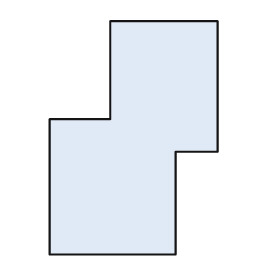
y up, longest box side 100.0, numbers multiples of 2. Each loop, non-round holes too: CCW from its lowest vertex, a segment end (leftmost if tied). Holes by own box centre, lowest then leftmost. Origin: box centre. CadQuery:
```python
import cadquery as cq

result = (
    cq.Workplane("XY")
    .moveTo(-36.0, -50.0)
    .lineTo(18.0, -50.0)
    .lineTo(18.0, -6.0)
    .lineTo(36.0, -6.0)
    .lineTo(36.0, 50.0)
    .lineTo(-10.0, 50.0)
    .lineTo(-10.0, 8.0)
    .lineTo(-36.0, 8.0)
    .close()
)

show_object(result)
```